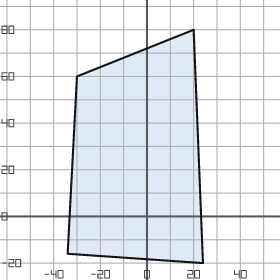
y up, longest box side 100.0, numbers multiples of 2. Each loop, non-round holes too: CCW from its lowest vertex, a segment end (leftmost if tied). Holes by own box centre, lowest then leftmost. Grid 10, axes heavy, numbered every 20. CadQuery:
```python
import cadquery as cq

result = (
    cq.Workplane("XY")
    .moveTo(24.0, -20.0)
    .lineTo(20.0, 80.0)
    .lineTo(-30.0, 60.0)
    .lineTo(-34.0, -16.0)
    .close()
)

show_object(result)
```